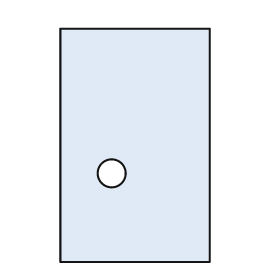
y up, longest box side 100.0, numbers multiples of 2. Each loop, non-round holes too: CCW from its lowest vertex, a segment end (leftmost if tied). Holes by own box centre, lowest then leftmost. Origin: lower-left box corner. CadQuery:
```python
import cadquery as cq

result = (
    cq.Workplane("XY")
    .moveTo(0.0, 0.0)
    .lineTo(64.0, 0.0)
    .lineTo(64.0, 100.0)
    .lineTo(0.0, 100.0)
    .close()
    .moveTo(22.0, 38.0)
    .circle(6.0)
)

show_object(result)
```